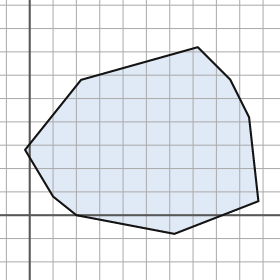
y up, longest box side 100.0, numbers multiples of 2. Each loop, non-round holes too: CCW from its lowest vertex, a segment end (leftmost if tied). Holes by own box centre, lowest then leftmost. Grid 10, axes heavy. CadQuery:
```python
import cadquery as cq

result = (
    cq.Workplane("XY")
    .moveTo(62.0, -8.0)
    .lineTo(98.0, 6.0)
    .lineTo(94.0, 42.0)
    .lineTo(86.0, 58.0)
    .lineTo(72.0, 72.0)
    .lineTo(22.0, 58.0)
    .lineTo(-2.0, 28.0)
    .lineTo(10.0, 8.0)
    .lineTo(20.0, 0.0)
    .close()
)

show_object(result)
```